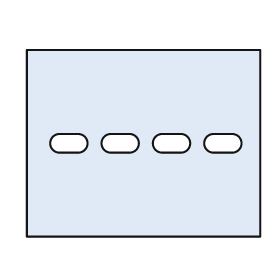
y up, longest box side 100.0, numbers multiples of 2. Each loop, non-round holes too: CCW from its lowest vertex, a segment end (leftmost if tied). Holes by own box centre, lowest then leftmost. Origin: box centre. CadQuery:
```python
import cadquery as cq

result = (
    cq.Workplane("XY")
    .moveTo(-50.0, -40.0)
    .lineTo(50.0, -40.0)
    .lineTo(50.0, 40.0)
    .lineTo(-50.0, 40.0)
    .close()
    .moveTo(-36.0, -4.0)
    .lineTo(-28.0, -4.0)
    .threePointArc((-24.0, 0.0), (-28.0, 4.0))
    .lineTo(-36.0, 4.0)
    .threePointArc((-40.0, 0.0), (-36.0, -4.0))
    .close()
    .moveTo(-14.0, -4.0)
    .lineTo(-6.0, -4.0)
    .threePointArc((-2.0, 0.0), (-6.0, 4.0))
    .lineTo(-14.0, 4.0)
    .threePointArc((-18.0, 0.0), (-14.0, -4.0))
    .close()
    .moveTo(8.0, -4.0)
    .lineTo(16.0, -4.0)
    .threePointArc((20.0, 0.0), (16.0, 4.0))
    .lineTo(8.0, 4.0)
    .threePointArc((4.0, 0.0), (8.0, -4.0))
    .close()
    .moveTo(30.0, -4.0)
    .lineTo(38.0, -4.0)
    .threePointArc((42.0, 0.0), (38.0, 4.0))
    .lineTo(30.0, 4.0)
    .threePointArc((26.0, 0.0), (30.0, -4.0))
    .close()
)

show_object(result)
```